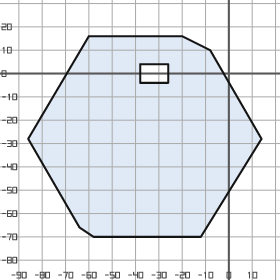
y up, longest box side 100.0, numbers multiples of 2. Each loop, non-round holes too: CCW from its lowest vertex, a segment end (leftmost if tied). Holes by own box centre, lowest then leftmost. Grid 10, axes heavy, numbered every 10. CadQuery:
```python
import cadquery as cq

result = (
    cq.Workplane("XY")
    .moveTo(-58.0, -70.0)
    .lineTo(-12.0, -70.0)
    .lineTo(14.0, -28.0)
    .lineTo(-8.0, 10.0)
    .lineTo(-20.0, 16.0)
    .lineTo(-60.0, 16.0)
    .lineTo(-86.0, -28.0)
    .lineTo(-64.0, -66.0)
    .close()
    .moveTo(-38.0, -4.0)
    .lineTo(-26.0, -4.0)
    .lineTo(-26.0, 4.0)
    .lineTo(-38.0, 4.0)
    .close()
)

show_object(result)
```